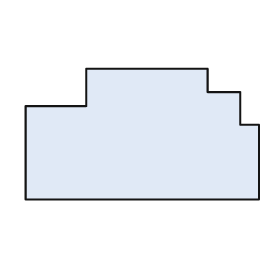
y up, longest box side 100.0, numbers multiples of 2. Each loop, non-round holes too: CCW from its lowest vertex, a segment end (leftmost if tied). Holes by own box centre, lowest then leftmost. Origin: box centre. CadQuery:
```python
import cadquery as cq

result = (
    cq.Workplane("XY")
    .moveTo(-50.0, -28.0)
    .lineTo(50.0, -28.0)
    .lineTo(50.0, 4.0)
    .lineTo(42.0, 4.0)
    .lineTo(42.0, 18.0)
    .lineTo(28.0, 18.0)
    .lineTo(28.0, 28.0)
    .lineTo(-24.0, 28.0)
    .lineTo(-24.0, 12.0)
    .lineTo(-50.0, 12.0)
    .close()
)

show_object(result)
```